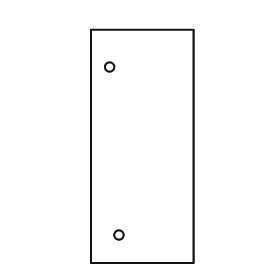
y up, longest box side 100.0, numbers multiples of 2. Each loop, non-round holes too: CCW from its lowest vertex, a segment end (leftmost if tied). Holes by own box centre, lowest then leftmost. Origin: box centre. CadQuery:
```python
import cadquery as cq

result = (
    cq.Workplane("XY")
    .moveTo(-22.0, -50.0)
    .lineTo(22.0, -50.0)
    .lineTo(22.0, 50.0)
    .lineTo(-22.0, 50.0)
    .close()
    .moveTo(-10.0, -38.0)
    .circle(2.0)
    .moveTo(-14.0, 34.0)
    .circle(2.0)
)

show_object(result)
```